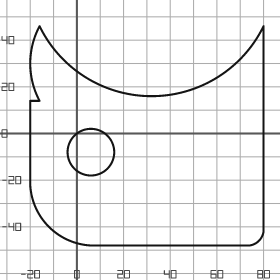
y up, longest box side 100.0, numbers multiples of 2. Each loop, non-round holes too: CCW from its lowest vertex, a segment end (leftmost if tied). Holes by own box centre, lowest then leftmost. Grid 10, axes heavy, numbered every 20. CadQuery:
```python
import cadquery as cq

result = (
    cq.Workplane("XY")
    .moveTo(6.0, -48.0)
    .lineTo(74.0, -48.0)
    .threePointArc((78.0, -46.0), (80.0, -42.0))
    .lineTo(80.0, 46.0)
    .threePointArc((32.0, 16.0), (-16.0, 46.0))
    .threePointArc((-20.0, 30.0), (-16.0, 14.0))
    .lineTo(-20.0, 14.0)
    .lineTo(-20.0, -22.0)
    .threePointArc((-12.0, -40.0), (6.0, -48.0))
    .close()
    .moveTo(6.0, -8.0)
    .circle(10.0)
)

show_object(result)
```